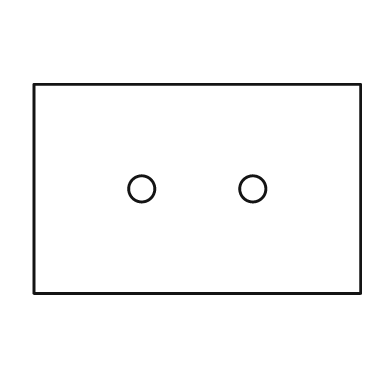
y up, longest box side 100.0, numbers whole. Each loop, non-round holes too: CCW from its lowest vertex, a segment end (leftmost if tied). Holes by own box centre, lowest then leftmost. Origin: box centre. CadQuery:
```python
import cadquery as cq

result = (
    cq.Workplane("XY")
    .moveTo(-50.0, -32.0)
    .lineTo(50.0, -32.0)
    .lineTo(50.0, 32.0)
    .lineTo(-50.0, 32.0)
    .close()
    .moveTo(-17.0, 0.0)
    .circle(4.0)
    .moveTo(17.0, 0.0)
    .circle(4.0)
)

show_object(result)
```